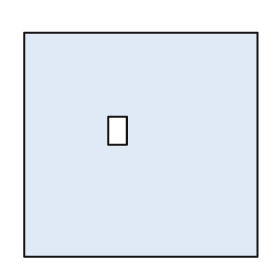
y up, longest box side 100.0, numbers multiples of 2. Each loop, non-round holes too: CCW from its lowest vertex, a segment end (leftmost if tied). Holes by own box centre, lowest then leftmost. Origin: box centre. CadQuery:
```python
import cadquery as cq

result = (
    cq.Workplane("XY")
    .moveTo(-50.0, -48.0)
    .lineTo(50.0, -48.0)
    .lineTo(50.0, 48.0)
    .lineTo(-50.0, 48.0)
    .close()
    .moveTo(-14.0, 0.0)
    .lineTo(-6.0, 0.0)
    .lineTo(-6.0, 12.0)
    .lineTo(-14.0, 12.0)
    .close()
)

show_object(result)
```